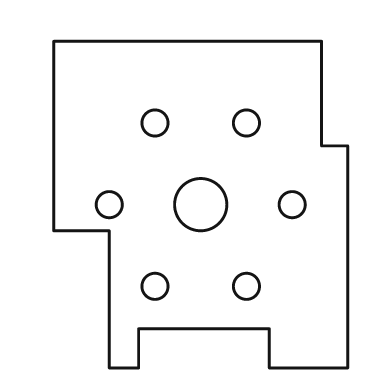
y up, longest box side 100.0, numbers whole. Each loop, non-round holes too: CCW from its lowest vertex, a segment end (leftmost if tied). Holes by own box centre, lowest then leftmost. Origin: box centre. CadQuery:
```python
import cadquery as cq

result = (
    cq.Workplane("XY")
    .moveTo(-28.0, -50.0)
    .lineTo(-19.0, -50.0)
    .lineTo(-19.0, -38.0)
    .lineTo(21.0, -38.0)
    .lineTo(21.0, -50.0)
    .lineTo(45.0, -50.0)
    .lineTo(45.0, 18.0)
    .lineTo(37.0, 18.0)
    .lineTo(37.0, 50.0)
    .lineTo(-45.0, 50.0)
    .lineTo(-45.0, -8.0)
    .lineTo(-28.0, -8.0)
    .close()
    .moveTo(-14.0, -25.0)
    .circle(4.0)
    .moveTo(14.0, -25.0)
    .circle(4.0)
    .moveTo(-28.0, 0.0)
    .circle(4.0)
    .moveTo(0.0, 0.0)
    .circle(8.0)
    .moveTo(28.0, 0.0)
    .circle(4.0)
    .moveTo(-14.0, 25.0)
    .circle(4.0)
    .moveTo(14.0, 25.0)
    .circle(4.0)
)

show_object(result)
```